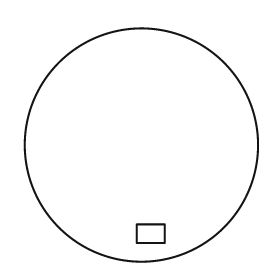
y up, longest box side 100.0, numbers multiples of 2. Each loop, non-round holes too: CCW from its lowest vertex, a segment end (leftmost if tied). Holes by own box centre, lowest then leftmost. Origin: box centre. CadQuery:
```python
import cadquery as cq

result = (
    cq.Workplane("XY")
    .moveTo(0.0, 0.0)
    .circle(50.0)
    .moveTo(-2.0, -42.0)
    .lineTo(10.0, -42.0)
    .lineTo(10.0, -34.0)
    .lineTo(-2.0, -34.0)
    .close()
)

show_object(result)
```